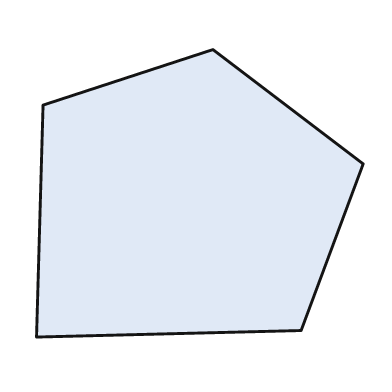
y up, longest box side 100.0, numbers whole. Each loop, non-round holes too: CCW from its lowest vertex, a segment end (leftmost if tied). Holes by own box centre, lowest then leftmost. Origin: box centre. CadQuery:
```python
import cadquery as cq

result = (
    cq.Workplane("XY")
    .moveTo(-50.0, -44.0)
    .lineTo(31.0, -42.0)
    .lineTo(50.0, 9.0)
    .lineTo(4.0, 44.0)
    .lineTo(-48.0, 27.0)
    .close()
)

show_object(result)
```